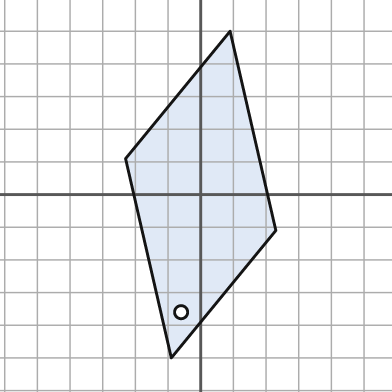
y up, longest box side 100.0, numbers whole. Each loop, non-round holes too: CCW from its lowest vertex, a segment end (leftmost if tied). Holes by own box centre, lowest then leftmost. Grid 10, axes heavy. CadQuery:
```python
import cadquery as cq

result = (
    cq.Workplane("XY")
    .moveTo(-9.0, -50.0)
    .lineTo(23.0, -11.0)
    .lineTo(9.0, 50.0)
    .lineTo(-23.0, 11.0)
    .close()
    .moveTo(-6.0, -36.0)
    .circle(2.0)
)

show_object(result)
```